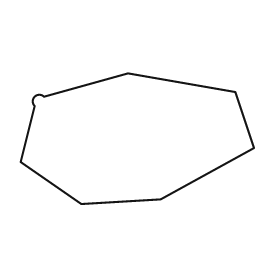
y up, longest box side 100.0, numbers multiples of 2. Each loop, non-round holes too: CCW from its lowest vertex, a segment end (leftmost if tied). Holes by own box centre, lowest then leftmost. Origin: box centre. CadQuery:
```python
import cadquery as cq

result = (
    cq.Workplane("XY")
    .moveTo(-24.0, -28.0)
    .lineTo(10.0, -26.0)
    .lineTo(50.0, -4.0)
    .lineTo(42.0, 20.0)
    .lineTo(-4.0, 28.0)
    .lineTo(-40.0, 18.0)
    .threePointArc((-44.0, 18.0), (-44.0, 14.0))
    .lineTo(-50.0, -10.0)
    .close()
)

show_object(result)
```